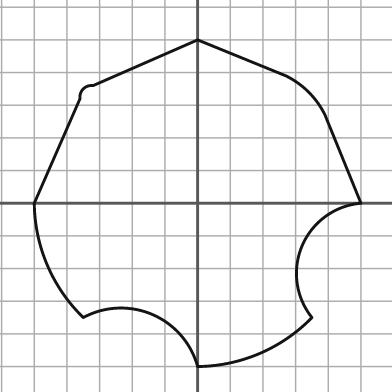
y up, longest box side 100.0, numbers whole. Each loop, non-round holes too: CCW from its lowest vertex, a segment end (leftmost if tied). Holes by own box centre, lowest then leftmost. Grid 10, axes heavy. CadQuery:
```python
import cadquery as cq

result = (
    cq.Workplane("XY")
    .moveTo(0.0, -50.0)
    .threePointArc((19.0, -46.0), (35.0, -35.0))
    .threePointArc((32.0, -13.0), (50.0, 0.0))
    .lineTo(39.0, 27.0)
    .threePointArc((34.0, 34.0), (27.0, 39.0))
    .lineTo(0.0, 50.0)
    .lineTo(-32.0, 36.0)
    .threePointArc((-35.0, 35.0), (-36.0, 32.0))
    .lineTo(-50.0, 0.0)
    .threePointArc((-46.0, -19.0), (-35.0, -35.0))
    .threePointArc((-14.0, -34.0), (0.0, -50.0))
    .close()
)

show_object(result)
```